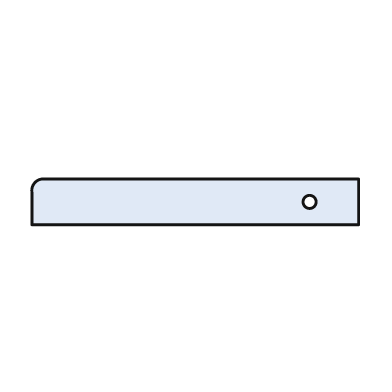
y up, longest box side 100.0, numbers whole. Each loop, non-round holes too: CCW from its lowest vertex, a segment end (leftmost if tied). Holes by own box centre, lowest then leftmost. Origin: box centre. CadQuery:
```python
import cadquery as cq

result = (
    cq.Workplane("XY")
    .moveTo(-50.0, -7.0)
    .lineTo(50.0, -7.0)
    .lineTo(50.0, 7.0)
    .lineTo(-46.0, 7.0)
    .threePointArc((-49.0, 6.0), (-50.0, 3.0))
    .close()
    .moveTo(35.0, 0.0)
    .circle(2.0)
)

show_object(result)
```